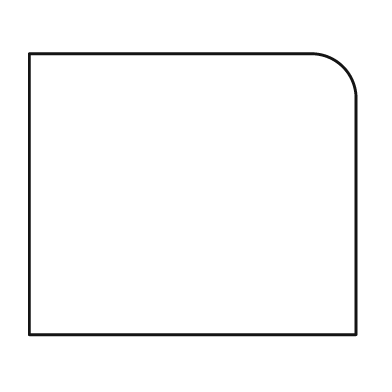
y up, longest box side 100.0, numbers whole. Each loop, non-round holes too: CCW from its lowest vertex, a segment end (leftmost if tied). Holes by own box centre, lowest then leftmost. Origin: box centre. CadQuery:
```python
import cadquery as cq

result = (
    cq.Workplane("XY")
    .moveTo(-50.0, -43.0)
    .lineTo(50.0, -43.0)
    .lineTo(50.0, 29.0)
    .threePointArc((46.0, 39.0), (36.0, 43.0))
    .lineTo(-50.0, 43.0)
    .close()
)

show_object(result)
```